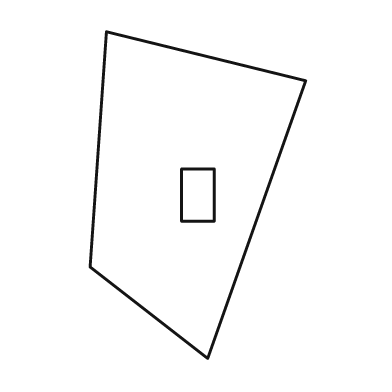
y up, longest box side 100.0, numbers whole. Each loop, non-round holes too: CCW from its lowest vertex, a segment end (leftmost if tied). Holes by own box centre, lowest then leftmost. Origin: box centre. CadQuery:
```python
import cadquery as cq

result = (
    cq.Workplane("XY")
    .moveTo(3.0, -50.0)
    .lineTo(33.0, 35.0)
    .lineTo(-28.0, 50.0)
    .lineTo(-33.0, -22.0)
    .close()
    .moveTo(-5.0, -8.0)
    .lineTo(5.0, -8.0)
    .lineTo(5.0, 8.0)
    .lineTo(-5.0, 8.0)
    .close()
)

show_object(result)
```